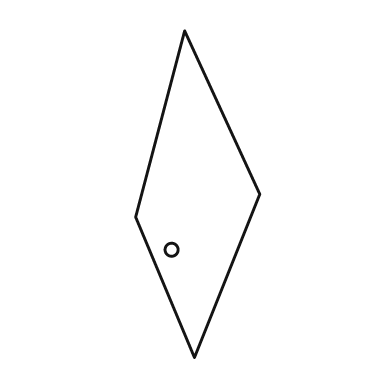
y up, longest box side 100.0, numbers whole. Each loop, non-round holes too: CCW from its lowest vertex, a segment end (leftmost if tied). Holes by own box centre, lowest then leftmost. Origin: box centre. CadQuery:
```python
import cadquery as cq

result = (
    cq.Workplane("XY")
    .moveTo(-1.0, -50.0)
    .lineTo(19.0, 0.0)
    .lineTo(-4.0, 50.0)
    .lineTo(-19.0, -7.0)
    .close()
    .moveTo(-8.0, -17.0)
    .circle(2.0)
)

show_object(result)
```